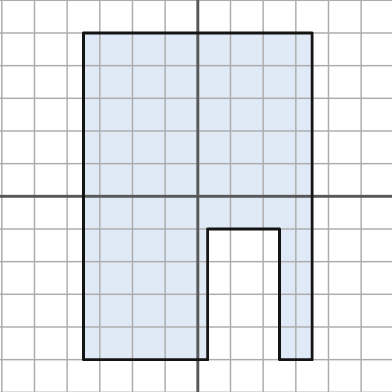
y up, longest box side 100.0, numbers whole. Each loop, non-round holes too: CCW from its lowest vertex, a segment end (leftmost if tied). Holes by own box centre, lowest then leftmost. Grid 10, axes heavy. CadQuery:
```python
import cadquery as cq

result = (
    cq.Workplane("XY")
    .moveTo(-35.0, -50.0)
    .lineTo(3.0, -50.0)
    .lineTo(3.0, -10.0)
    .lineTo(25.0, -10.0)
    .lineTo(25.0, -50.0)
    .lineTo(35.0, -50.0)
    .lineTo(35.0, 50.0)
    .lineTo(-35.0, 50.0)
    .close()
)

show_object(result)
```